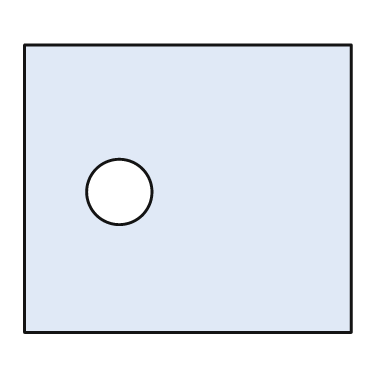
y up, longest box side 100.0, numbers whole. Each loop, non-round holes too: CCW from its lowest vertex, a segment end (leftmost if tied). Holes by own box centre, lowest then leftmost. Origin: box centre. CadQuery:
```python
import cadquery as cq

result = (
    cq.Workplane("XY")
    .moveTo(-50.0, -44.0)
    .lineTo(50.0, -44.0)
    .lineTo(50.0, 44.0)
    .lineTo(-50.0, 44.0)
    .close()
    .moveTo(-21.0, -1.0)
    .circle(10.0)
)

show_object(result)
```